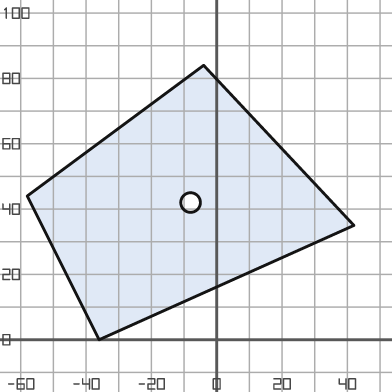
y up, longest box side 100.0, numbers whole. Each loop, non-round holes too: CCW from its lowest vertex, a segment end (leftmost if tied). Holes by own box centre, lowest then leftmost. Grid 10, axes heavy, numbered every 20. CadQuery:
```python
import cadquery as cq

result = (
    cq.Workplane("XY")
    .moveTo(-36.0, 0.0)
    .lineTo(42.0, 35.0)
    .lineTo(-4.0, 84.0)
    .lineTo(-58.0, 44.0)
    .close()
    .moveTo(-8.0, 42.0)
    .circle(3.0)
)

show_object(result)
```